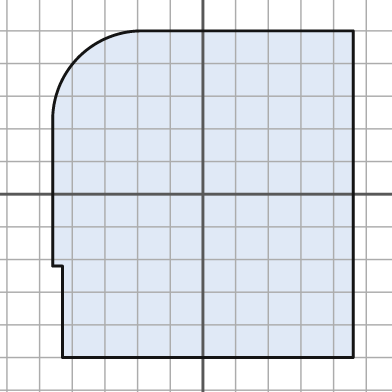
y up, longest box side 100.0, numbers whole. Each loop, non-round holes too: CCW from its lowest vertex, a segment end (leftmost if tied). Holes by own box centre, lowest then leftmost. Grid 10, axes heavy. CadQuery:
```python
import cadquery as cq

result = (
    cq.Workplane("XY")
    .moveTo(-43.0, -50.0)
    .lineTo(46.0, -50.0)
    .lineTo(46.0, 50.0)
    .lineTo(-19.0, 50.0)
    .threePointArc((-38.0, 42.0), (-46.0, 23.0))
    .lineTo(-46.0, -22.0)
    .lineTo(-43.0, -22.0)
    .close()
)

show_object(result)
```